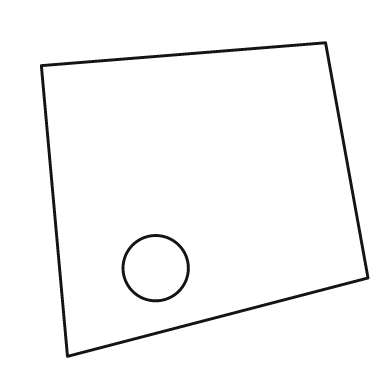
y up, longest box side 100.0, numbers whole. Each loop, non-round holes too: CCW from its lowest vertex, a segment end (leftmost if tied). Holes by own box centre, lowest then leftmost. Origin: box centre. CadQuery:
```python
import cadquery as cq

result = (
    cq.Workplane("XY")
    .moveTo(-42.0, -48.0)
    .lineTo(50.0, -24.0)
    .lineTo(37.0, 48.0)
    .lineTo(-50.0, 41.0)
    .close()
    .moveTo(-15.0, -21.0)
    .circle(10.0)
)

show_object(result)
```